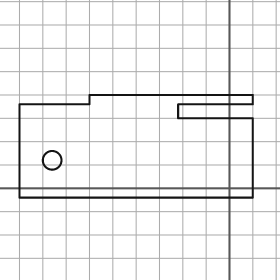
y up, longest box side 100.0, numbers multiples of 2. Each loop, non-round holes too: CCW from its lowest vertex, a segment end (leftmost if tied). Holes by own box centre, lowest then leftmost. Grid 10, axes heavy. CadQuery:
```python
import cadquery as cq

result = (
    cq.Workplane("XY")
    .moveTo(-90.0, -4.0)
    .lineTo(10.0, -4.0)
    .lineTo(10.0, 30.0)
    .lineTo(-22.0, 30.0)
    .lineTo(-22.0, 36.0)
    .lineTo(10.0, 36.0)
    .lineTo(10.0, 40.0)
    .lineTo(-60.0, 40.0)
    .lineTo(-60.0, 36.0)
    .lineTo(-90.0, 36.0)
    .close()
    .moveTo(-76.0, 12.0)
    .circle(4.0)
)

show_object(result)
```